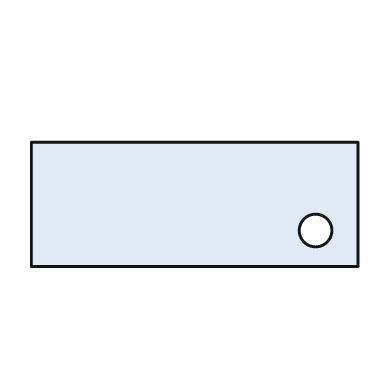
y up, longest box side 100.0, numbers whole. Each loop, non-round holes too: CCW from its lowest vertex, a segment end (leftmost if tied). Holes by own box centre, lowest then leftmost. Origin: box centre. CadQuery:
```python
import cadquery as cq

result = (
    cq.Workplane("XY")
    .moveTo(-50.0, -19.0)
    .lineTo(50.0, -19.0)
    .lineTo(50.0, 19.0)
    .lineTo(-50.0, 19.0)
    .close()
    .moveTo(37.0, -8.0)
    .circle(5.0)
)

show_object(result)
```